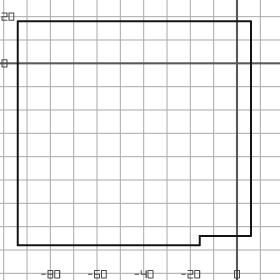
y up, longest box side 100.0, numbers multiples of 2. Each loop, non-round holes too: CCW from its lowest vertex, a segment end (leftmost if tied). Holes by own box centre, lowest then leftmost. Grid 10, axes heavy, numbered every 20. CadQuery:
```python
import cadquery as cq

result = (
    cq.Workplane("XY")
    .moveTo(-94.0, -78.0)
    .lineTo(-16.0, -78.0)
    .lineTo(-16.0, -74.0)
    .lineTo(6.0, -74.0)
    .lineTo(6.0, 18.0)
    .lineTo(-94.0, 18.0)
    .close()
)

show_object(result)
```